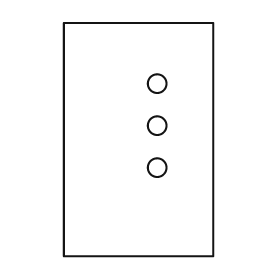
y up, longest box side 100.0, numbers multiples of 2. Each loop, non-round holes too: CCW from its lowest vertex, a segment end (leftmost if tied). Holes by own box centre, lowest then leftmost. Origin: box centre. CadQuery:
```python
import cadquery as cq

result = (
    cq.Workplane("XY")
    .moveTo(-32.0, -50.0)
    .lineTo(32.0, -50.0)
    .lineTo(32.0, 50.0)
    .lineTo(-32.0, 50.0)
    .close()
    .moveTo(8.0, -12.0)
    .circle(4.0)
    .moveTo(8.0, 6.0)
    .circle(4.0)
    .moveTo(8.0, 24.0)
    .circle(4.0)
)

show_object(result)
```